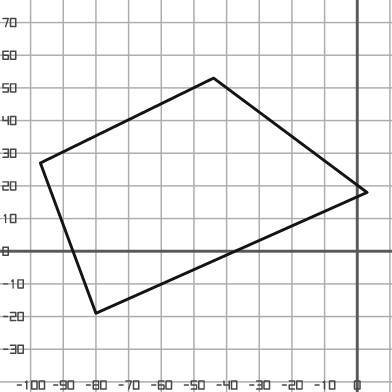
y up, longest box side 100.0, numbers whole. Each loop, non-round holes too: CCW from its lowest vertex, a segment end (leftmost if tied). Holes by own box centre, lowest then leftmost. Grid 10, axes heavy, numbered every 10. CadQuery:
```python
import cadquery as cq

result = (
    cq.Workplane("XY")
    .moveTo(-80.0, -19.0)
    .lineTo(3.0, 18.0)
    .lineTo(-44.0, 53.0)
    .lineTo(-97.0, 27.0)
    .close()
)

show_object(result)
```